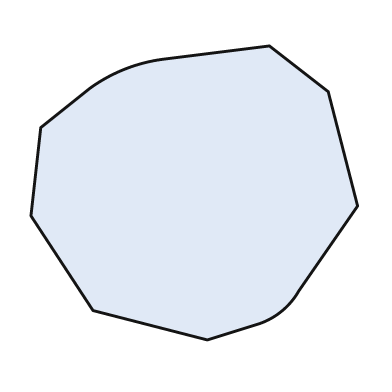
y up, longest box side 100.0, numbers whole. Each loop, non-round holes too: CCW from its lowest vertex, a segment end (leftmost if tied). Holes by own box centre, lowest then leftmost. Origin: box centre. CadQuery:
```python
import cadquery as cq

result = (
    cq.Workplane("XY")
    .moveTo(4.0, -45.0)
    .lineTo(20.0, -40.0)
    .threePointArc((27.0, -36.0), (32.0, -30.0))
    .lineTo(50.0, -4.0)
    .lineTo(41.0, 31.0)
    .lineTo(23.0, 45.0)
    .lineTo(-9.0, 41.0)
    .threePointArc((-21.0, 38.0), (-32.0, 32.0))
    .lineTo(-47.0, 20.0)
    .lineTo(-50.0, -7.0)
    .lineTo(-31.0, -36.0)
    .close()
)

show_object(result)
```